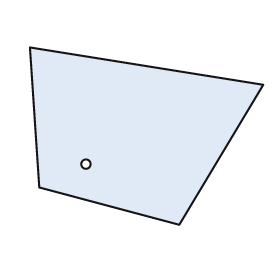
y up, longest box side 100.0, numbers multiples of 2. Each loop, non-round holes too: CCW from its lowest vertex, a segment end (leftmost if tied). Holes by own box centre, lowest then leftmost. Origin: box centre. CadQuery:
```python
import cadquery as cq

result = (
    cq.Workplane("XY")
    .moveTo(14.0, -38.0)
    .lineTo(50.0, 22.0)
    .lineTo(-50.0, 38.0)
    .lineTo(-46.0, -22.0)
    .close()
    .moveTo(-26.0, -12.0)
    .circle(2.0)
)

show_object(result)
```